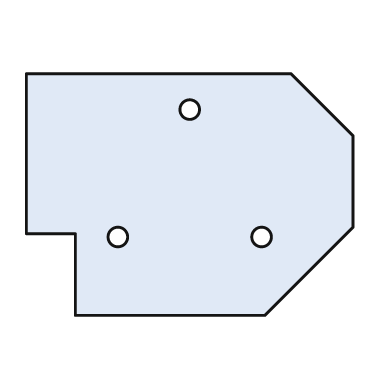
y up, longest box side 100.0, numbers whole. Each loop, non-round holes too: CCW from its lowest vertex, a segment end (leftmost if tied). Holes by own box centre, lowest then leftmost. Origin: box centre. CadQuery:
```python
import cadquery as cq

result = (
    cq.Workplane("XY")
    .moveTo(-35.0, -37.0)
    .lineTo(23.0, -37.0)
    .lineTo(50.0, -10.0)
    .lineTo(50.0, 18.0)
    .lineTo(31.0, 37.0)
    .lineTo(-50.0, 37.0)
    .lineTo(-50.0, -12.0)
    .lineTo(-35.0, -12.0)
    .close()
    .moveTo(-22.0, -13.0)
    .circle(3.0)
    .moveTo(22.0, -13.0)
    .circle(3.0)
    .moveTo(0.0, 26.0)
    .circle(3.0)
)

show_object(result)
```